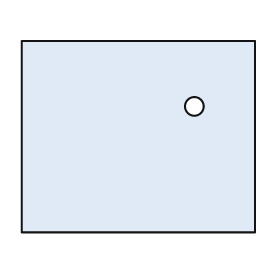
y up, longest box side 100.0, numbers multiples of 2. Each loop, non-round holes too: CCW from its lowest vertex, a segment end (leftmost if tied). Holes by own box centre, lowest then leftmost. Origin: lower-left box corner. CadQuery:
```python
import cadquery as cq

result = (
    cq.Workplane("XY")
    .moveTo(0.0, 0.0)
    .lineTo(100.0, 0.0)
    .lineTo(100.0, 82.0)
    .lineTo(0.0, 82.0)
    .close()
    .moveTo(74.0, 54.0)
    .circle(4.0)
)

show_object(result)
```